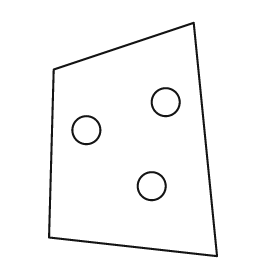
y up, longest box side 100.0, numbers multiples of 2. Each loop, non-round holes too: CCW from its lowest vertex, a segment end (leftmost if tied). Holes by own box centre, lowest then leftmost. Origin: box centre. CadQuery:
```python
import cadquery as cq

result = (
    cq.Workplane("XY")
    .moveTo(36.0, -50.0)
    .lineTo(26.0, 50.0)
    .lineTo(-34.0, 30.0)
    .lineTo(-36.0, -42.0)
    .close()
    .moveTo(8.0, -20.0)
    .circle(6.0)
    .moveTo(-20.0, 4.0)
    .circle(6.0)
    .moveTo(14.0, 16.0)
    .circle(6.0)
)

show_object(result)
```